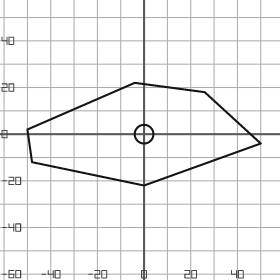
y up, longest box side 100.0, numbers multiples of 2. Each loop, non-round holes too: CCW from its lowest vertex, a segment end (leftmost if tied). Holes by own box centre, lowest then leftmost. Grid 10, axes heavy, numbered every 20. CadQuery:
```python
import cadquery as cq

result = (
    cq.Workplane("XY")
    .moveTo(0.0, -22.0)
    .lineTo(50.0, -4.0)
    .lineTo(26.0, 18.0)
    .lineTo(-4.0, 22.0)
    .lineTo(-50.0, 2.0)
    .lineTo(-48.0, -12.0)
    .close()
    .moveTo(0.0, 0.0)
    .circle(4.0)
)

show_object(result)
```